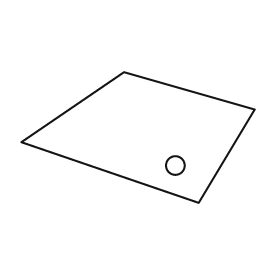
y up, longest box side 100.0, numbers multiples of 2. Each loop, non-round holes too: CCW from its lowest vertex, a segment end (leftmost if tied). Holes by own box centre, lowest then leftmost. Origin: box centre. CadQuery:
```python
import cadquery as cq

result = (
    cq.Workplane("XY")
    .moveTo(26.0, -28.0)
    .lineTo(50.0, 12.0)
    .lineTo(-6.0, 28.0)
    .lineTo(-50.0, -2.0)
    .close()
    .moveTo(16.0, -12.0)
    .circle(4.0)
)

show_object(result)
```